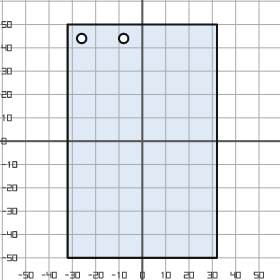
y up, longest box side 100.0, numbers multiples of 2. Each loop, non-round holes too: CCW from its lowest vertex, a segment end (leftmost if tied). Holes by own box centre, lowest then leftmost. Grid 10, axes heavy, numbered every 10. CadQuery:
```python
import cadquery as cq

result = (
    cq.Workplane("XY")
    .moveTo(-32.0, -50.0)
    .lineTo(32.0, -50.0)
    .lineTo(32.0, 50.0)
    .lineTo(-32.0, 50.0)
    .close()
    .moveTo(-26.0, 44.0)
    .circle(2.0)
    .moveTo(-8.0, 44.0)
    .circle(2.0)
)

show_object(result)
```